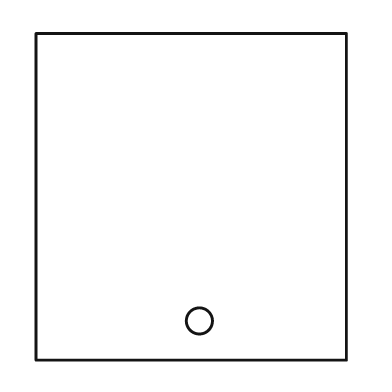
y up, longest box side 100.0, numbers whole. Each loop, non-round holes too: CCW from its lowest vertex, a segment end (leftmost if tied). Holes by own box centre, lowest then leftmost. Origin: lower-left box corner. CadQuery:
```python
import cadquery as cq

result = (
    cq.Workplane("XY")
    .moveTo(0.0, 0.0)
    .lineTo(95.0, 0.0)
    .lineTo(95.0, 100.0)
    .lineTo(0.0, 100.0)
    .close()
    .moveTo(50.0, 12.0)
    .circle(4.0)
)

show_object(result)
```